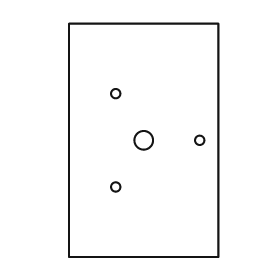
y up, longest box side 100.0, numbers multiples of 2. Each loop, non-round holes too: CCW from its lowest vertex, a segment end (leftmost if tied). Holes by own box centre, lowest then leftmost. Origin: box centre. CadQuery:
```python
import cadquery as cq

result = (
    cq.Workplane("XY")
    .moveTo(-32.0, -50.0)
    .lineTo(32.0, -50.0)
    .lineTo(32.0, 50.0)
    .lineTo(-32.0, 50.0)
    .close()
    .moveTo(-12.0, -20.0)
    .circle(2.0)
    .moveTo(0.0, 0.0)
    .circle(4.0)
    .moveTo(24.0, 0.0)
    .circle(2.0)
    .moveTo(-12.0, 20.0)
    .circle(2.0)
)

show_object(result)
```